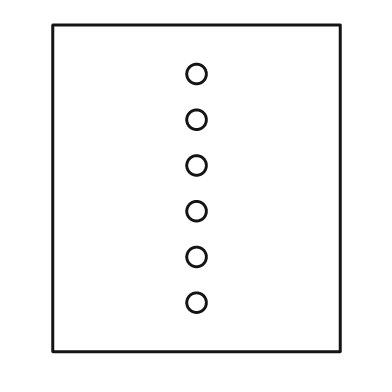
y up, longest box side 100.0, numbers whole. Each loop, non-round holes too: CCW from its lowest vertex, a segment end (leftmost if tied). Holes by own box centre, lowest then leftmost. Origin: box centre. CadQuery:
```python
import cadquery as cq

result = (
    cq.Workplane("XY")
    .moveTo(-44.0, -50.0)
    .lineTo(44.0, -50.0)
    .lineTo(44.0, 50.0)
    .lineTo(-44.0, 50.0)
    .close()
    .moveTo(0.0, -35.0)
    .circle(3.0)
    .moveTo(0.0, -21.0)
    .circle(3.0)
    .moveTo(0.0, -7.0)
    .circle(3.0)
    .moveTo(0.0, 7.0)
    .circle(3.0)
    .moveTo(0.0, 21.0)
    .circle(3.0)
    .moveTo(0.0, 35.0)
    .circle(3.0)
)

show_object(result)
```